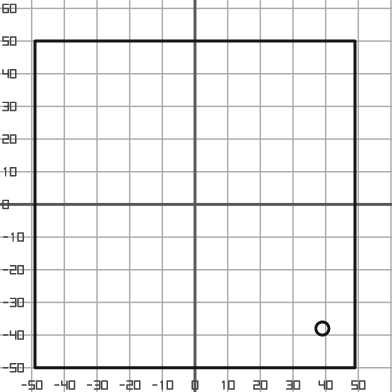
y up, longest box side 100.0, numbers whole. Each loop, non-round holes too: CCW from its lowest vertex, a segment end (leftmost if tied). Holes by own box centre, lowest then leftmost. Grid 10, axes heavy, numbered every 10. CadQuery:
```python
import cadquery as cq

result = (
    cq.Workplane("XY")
    .moveTo(-49.0, -50.0)
    .lineTo(49.0, -50.0)
    .lineTo(49.0, 50.0)
    .lineTo(-49.0, 50.0)
    .close()
    .moveTo(39.0, -38.0)
    .circle(2.0)
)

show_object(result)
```